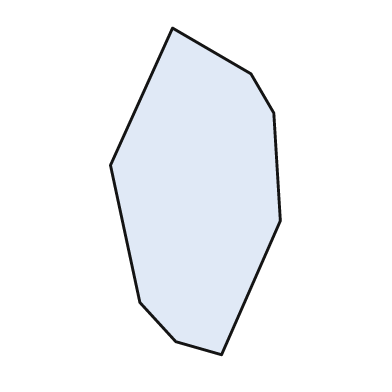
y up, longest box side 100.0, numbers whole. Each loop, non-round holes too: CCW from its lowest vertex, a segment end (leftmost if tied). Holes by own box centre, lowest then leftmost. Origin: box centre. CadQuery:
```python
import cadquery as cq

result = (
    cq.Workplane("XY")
    .moveTo(8.0, -50.0)
    .lineTo(26.0, -9.0)
    .lineTo(24.0, 24.0)
    .lineTo(17.0, 36.0)
    .lineTo(-7.0, 50.0)
    .lineTo(-26.0, 8.0)
    .lineTo(-17.0, -34.0)
    .lineTo(-6.0, -46.0)
    .close()
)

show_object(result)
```